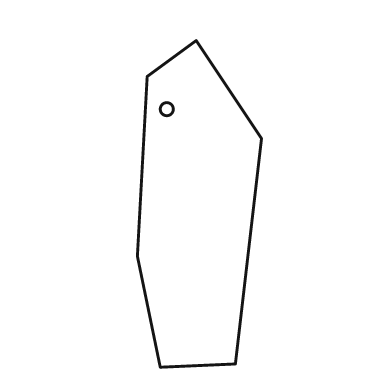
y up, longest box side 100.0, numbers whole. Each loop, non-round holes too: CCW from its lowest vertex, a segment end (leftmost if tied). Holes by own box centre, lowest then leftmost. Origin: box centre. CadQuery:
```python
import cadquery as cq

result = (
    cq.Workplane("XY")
    .moveTo(-12.0, -50.0)
    .lineTo(11.0, -49.0)
    .lineTo(19.0, 20.0)
    .lineTo(-1.0, 50.0)
    .lineTo(-16.0, 39.0)
    .lineTo(-19.0, -16.0)
    .close()
    .moveTo(-10.0, 29.0)
    .circle(2.0)
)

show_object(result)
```